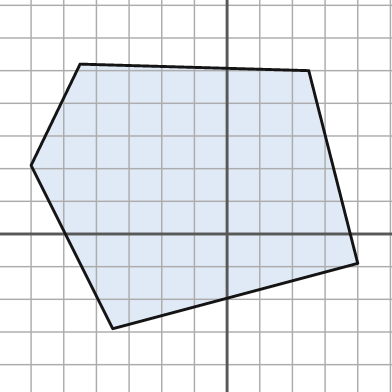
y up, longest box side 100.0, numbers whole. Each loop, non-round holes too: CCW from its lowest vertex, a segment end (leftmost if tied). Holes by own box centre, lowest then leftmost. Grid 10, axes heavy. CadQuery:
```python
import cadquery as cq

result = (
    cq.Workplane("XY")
    .moveTo(-35.0, -29.0)
    .lineTo(40.0, -9.0)
    .lineTo(25.0, 50.0)
    .lineTo(-45.0, 52.0)
    .lineTo(-60.0, 21.0)
    .close()
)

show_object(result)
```